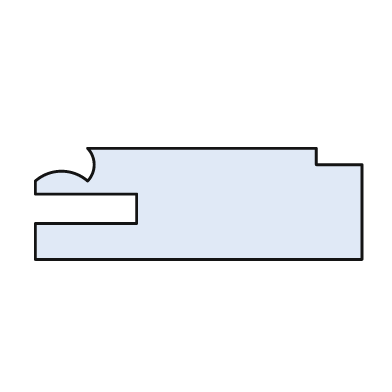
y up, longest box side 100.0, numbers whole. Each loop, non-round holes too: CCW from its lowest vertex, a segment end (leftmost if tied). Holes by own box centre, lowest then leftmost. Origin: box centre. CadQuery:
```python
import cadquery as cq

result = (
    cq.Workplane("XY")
    .moveTo(-50.0, -17.0)
    .lineTo(50.0, -17.0)
    .lineTo(50.0, 12.0)
    .lineTo(36.0, 12.0)
    .lineTo(36.0, 17.0)
    .lineTo(-34.0, 17.0)
    .threePointArc((-32.0, 12.0), (-34.0, 7.0))
    .threePointArc((-42.0, 10.0), (-50.0, 7.0))
    .lineTo(-50.0, 3.0)
    .lineTo(-19.0, 3.0)
    .lineTo(-19.0, -6.0)
    .lineTo(-50.0, -6.0)
    .close()
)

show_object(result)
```